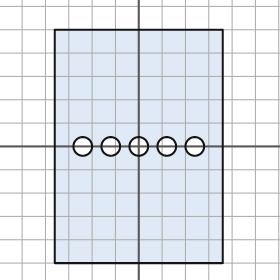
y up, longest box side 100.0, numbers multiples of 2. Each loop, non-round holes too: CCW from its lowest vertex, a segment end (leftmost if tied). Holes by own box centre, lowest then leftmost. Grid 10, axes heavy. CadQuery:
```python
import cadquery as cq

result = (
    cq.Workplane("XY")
    .moveTo(-36.0, -50.0)
    .lineTo(36.0, -50.0)
    .lineTo(36.0, 50.0)
    .lineTo(-36.0, 50.0)
    .close()
    .moveTo(-24.0, 0.0)
    .circle(4.0)
    .moveTo(-12.0, 0.0)
    .circle(4.0)
    .moveTo(0.0, 0.0)
    .circle(4.0)
    .moveTo(12.0, 0.0)
    .circle(4.0)
    .moveTo(24.0, 0.0)
    .circle(4.0)
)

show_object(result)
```